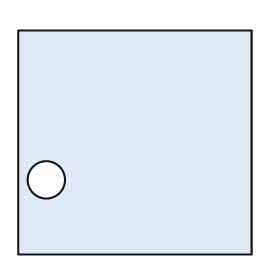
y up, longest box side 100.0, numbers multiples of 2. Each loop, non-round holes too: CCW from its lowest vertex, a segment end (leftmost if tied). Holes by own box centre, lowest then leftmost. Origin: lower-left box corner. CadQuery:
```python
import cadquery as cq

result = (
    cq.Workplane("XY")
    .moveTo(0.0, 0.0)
    .lineTo(100.0, 0.0)
    .lineTo(100.0, 96.0)
    .lineTo(0.0, 96.0)
    .close()
    .moveTo(12.0, 32.0)
    .circle(8.0)
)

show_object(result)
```